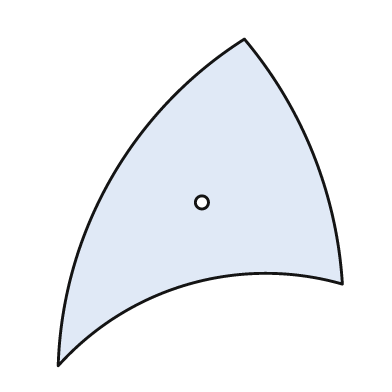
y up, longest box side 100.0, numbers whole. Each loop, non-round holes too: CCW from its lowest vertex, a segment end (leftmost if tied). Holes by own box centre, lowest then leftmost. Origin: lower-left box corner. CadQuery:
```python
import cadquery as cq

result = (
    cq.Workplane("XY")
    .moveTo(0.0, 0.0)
    .threePointArc((40.0, 25.0), (87.0, 25.0))
    .threePointArc((78.0, 65.0), (57.0, 100.0))
    .threePointArc((16.0, 57.0), (0.0, 0.0))
    .close()
    .moveTo(44.0, 50.0)
    .circle(2.0)
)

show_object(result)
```